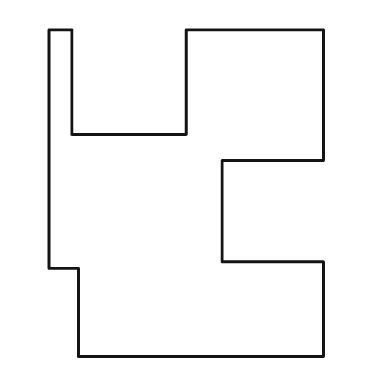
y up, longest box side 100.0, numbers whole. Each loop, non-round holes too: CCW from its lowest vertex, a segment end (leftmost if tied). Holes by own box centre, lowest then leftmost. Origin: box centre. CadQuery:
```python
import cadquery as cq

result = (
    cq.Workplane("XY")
    .moveTo(-33.0, -50.0)
    .lineTo(42.0, -50.0)
    .lineTo(42.0, -21.0)
    .lineTo(11.0, -21.0)
    .lineTo(11.0, 10.0)
    .lineTo(42.0, 10.0)
    .lineTo(42.0, 50.0)
    .lineTo(0.0, 50.0)
    .lineTo(0.0, 18.0)
    .lineTo(-35.0, 18.0)
    .lineTo(-35.0, 50.0)
    .lineTo(-42.0, 50.0)
    .lineTo(-42.0, -23.0)
    .lineTo(-33.0, -23.0)
    .close()
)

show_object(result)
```